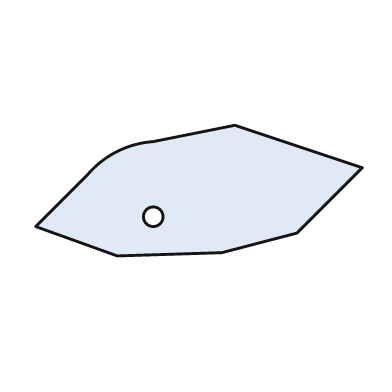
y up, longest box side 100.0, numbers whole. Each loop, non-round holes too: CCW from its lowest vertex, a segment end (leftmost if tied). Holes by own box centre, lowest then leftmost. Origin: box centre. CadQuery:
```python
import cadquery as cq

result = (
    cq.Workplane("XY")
    .moveTo(-25.0, -20.0)
    .lineTo(7.0, -19.0)
    .lineTo(30.0, -13.0)
    .lineTo(50.0, 7.0)
    .lineTo(11.0, 20.0)
    .lineTo(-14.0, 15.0)
    .threePointArc((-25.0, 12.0), (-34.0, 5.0))
    .lineTo(-50.0, -11.0)
    .close()
    .moveTo(-14.0, -8.0)
    .circle(3.0)
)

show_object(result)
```